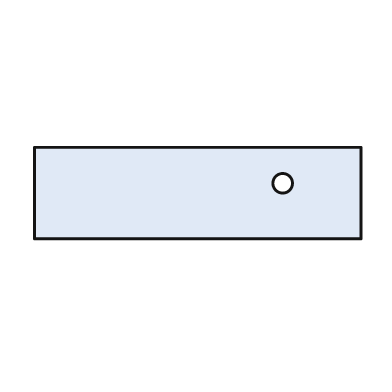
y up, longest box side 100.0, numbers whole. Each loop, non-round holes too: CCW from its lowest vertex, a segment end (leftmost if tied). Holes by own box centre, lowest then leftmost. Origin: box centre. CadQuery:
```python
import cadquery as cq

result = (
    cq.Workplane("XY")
    .moveTo(-50.0, -14.0)
    .lineTo(50.0, -14.0)
    .lineTo(50.0, 14.0)
    .lineTo(-50.0, 14.0)
    .close()
    .moveTo(26.0, 3.0)
    .circle(3.0)
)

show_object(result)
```